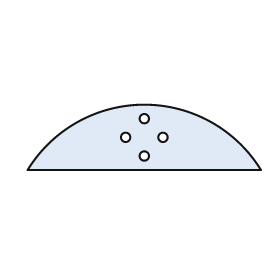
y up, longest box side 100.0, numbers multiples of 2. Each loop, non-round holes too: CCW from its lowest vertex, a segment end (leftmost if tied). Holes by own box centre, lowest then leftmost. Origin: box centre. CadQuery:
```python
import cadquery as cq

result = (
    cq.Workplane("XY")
    .moveTo(-50.0, -14.0)
    .lineTo(50.0, -14.0)
    .threePointArc((0.0, 14.0), (-50.0, -14.0))
    .close()
    .moveTo(0.0, -8.0)
    .circle(2.0)
    .moveTo(-8.0, 0.0)
    .circle(2.0)
    .moveTo(8.0, 0.0)
    .circle(2.0)
    .moveTo(0.0, 8.0)
    .circle(2.0)
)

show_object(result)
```